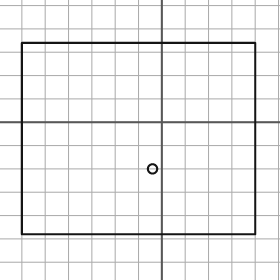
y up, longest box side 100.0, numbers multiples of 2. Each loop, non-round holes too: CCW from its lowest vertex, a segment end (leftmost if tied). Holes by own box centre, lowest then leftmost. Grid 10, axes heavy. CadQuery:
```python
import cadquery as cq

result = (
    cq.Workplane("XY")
    .moveTo(-60.0, -48.0)
    .lineTo(40.0, -48.0)
    .lineTo(40.0, 34.0)
    .lineTo(-60.0, 34.0)
    .close()
    .moveTo(-4.0, -20.0)
    .circle(2.0)
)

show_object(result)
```